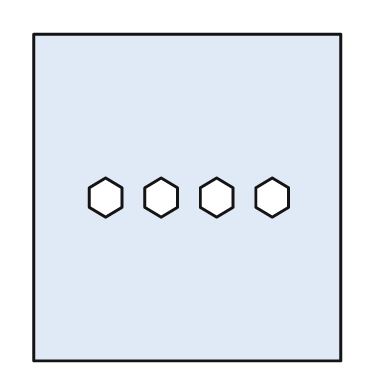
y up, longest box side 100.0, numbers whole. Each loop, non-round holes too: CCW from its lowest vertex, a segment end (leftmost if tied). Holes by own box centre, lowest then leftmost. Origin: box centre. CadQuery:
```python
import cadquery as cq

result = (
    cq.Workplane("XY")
    .moveTo(-47.0, -50.0)
    .lineTo(47.0, -50.0)
    .lineTo(47.0, 50.0)
    .lineTo(-47.0, 50.0)
    .close()
    .moveTo(-25.0, -6.0)
    .lineTo(-20.0, -3.0)
    .lineTo(-20.0, 3.0)
    .lineTo(-25.0, 6.0)
    .lineTo(-30.0, 3.0)
    .lineTo(-30.0, -3.0)
    .close()
    .moveTo(-8.0, -6.0)
    .lineTo(-3.0, -3.0)
    .lineTo(-3.0, 3.0)
    .lineTo(-8.0, 6.0)
    .lineTo(-13.0, 3.0)
    .lineTo(-13.0, -3.0)
    .close()
    .moveTo(9.0, -6.0)
    .lineTo(14.0, -3.0)
    .lineTo(14.0, 3.0)
    .lineTo(9.0, 6.0)
    .lineTo(4.0, 3.0)
    .lineTo(4.0, -3.0)
    .close()
    .moveTo(26.0, -6.0)
    .lineTo(31.0, -3.0)
    .lineTo(31.0, 3.0)
    .lineTo(26.0, 6.0)
    .lineTo(21.0, 3.0)
    .lineTo(21.0, -3.0)
    .close()
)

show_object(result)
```